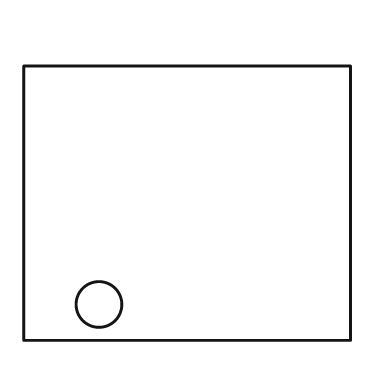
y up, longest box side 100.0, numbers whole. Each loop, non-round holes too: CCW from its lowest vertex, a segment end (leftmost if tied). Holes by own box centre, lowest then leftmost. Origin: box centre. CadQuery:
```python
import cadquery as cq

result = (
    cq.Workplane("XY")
    .moveTo(-50.0, -42.0)
    .lineTo(50.0, -42.0)
    .lineTo(50.0, 42.0)
    .lineTo(-50.0, 42.0)
    .close()
    .moveTo(-27.0, -31.0)
    .circle(7.0)
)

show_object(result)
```